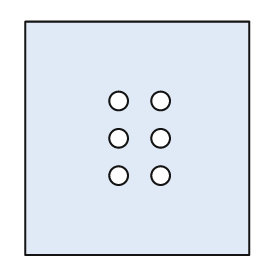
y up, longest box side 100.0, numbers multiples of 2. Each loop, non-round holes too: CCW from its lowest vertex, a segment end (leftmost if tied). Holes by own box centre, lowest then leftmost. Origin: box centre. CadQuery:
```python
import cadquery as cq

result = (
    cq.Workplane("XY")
    .moveTo(-48.0, -50.0)
    .lineTo(48.0, -50.0)
    .lineTo(48.0, 50.0)
    .lineTo(-48.0, 50.0)
    .close()
    .moveTo(-8.0, -16.0)
    .circle(4.0)
    .moveTo(10.0, -16.0)
    .circle(4.0)
    .moveTo(-8.0, 0.0)
    .circle(4.0)
    .moveTo(10.0, 0.0)
    .circle(4.0)
    .moveTo(-8.0, 16.0)
    .circle(4.0)
    .moveTo(10.0, 16.0)
    .circle(4.0)
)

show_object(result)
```